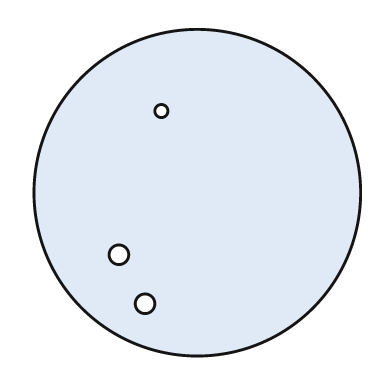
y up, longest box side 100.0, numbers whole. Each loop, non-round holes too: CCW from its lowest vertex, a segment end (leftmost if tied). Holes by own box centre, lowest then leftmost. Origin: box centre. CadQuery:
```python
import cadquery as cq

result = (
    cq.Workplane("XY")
    .moveTo(0.0, 0.0)
    .circle(50.0)
    .moveTo(-16.0, -34.0)
    .circle(3.0)
    .moveTo(-24.0, -19.0)
    .circle(3.0)
    .moveTo(-11.0, 25.0)
    .circle(2.0)
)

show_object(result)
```